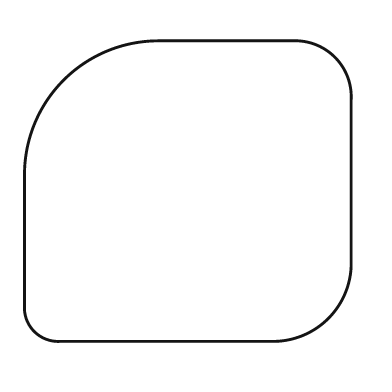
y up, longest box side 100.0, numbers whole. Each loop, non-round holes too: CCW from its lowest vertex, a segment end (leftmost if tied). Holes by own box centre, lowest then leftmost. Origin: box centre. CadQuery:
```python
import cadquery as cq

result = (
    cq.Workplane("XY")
    .moveTo(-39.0, -46.0)
    .lineTo(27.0, -46.0)
    .threePointArc((43.0, -39.0), (50.0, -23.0))
    .lineTo(50.0, 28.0)
    .threePointArc((45.0, 41.0), (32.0, 46.0))
    .lineTo(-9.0, 46.0)
    .threePointArc((-38.0, 34.0), (-50.0, 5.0))
    .lineTo(-50.0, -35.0)
    .threePointArc((-47.0, -43.0), (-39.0, -46.0))
    .close()
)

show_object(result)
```